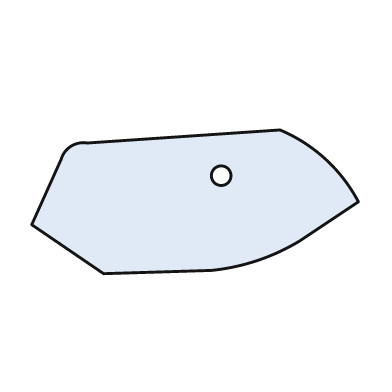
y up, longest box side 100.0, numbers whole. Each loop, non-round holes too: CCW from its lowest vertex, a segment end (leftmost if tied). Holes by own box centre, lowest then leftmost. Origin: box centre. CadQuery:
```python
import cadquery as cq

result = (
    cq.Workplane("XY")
    .moveTo(-28.0, -22.0)
    .lineTo(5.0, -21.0)
    .threePointArc((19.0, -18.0), (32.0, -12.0))
    .lineTo(50.0, 0.0)
    .threePointArc((40.0, 13.0), (26.0, 22.0))
    .lineTo(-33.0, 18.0)
    .threePointArc((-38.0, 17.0), (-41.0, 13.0))
    .lineTo(-50.0, -7.0)
    .close()
    .moveTo(8.0, 8.0)
    .circle(3.0)
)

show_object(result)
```